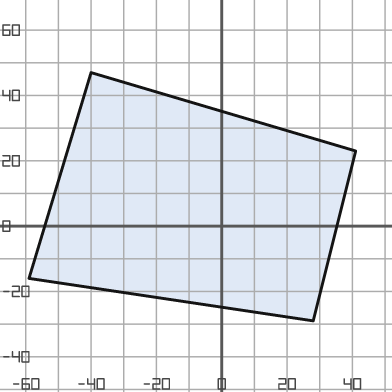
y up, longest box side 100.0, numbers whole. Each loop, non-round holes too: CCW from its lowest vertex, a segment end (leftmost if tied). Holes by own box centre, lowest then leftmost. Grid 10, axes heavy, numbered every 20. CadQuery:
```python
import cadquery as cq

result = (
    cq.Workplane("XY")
    .moveTo(28.0, -29.0)
    .lineTo(41.0, 23.0)
    .lineTo(-40.0, 47.0)
    .lineTo(-59.0, -16.0)
    .close()
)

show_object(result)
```